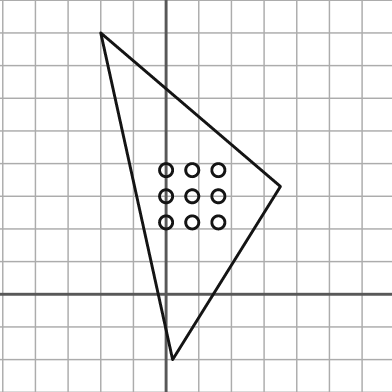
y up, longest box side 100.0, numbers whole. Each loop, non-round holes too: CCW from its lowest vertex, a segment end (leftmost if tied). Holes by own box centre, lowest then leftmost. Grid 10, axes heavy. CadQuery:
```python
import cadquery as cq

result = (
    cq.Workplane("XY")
    .moveTo(2.0, -20.0)
    .lineTo(35.0, 33.0)
    .lineTo(-20.0, 80.0)
    .close()
    .moveTo(0.0, 22.0)
    .circle(2.0)
    .moveTo(8.0, 22.0)
    .circle(2.0)
    .moveTo(16.0, 22.0)
    .circle(2.0)
    .moveTo(0.0, 30.0)
    .circle(2.0)
    .moveTo(8.0, 30.0)
    .circle(2.0)
    .moveTo(16.0, 30.0)
    .circle(2.0)
    .moveTo(0.0, 38.0)
    .circle(2.0)
    .moveTo(8.0, 38.0)
    .circle(2.0)
    .moveTo(16.0, 38.0)
    .circle(2.0)
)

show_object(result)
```